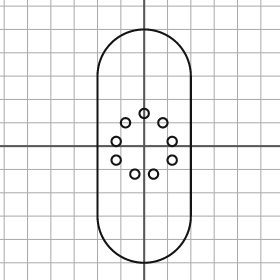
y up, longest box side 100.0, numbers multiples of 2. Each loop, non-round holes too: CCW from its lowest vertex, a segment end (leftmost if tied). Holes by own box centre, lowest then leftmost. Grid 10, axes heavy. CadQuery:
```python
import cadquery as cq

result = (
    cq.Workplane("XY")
    .moveTo(-20.0, -30.0)
    .threePointArc((0.0, -50.0), (20.0, -30.0))
    .lineTo(20.0, 30.0)
    .threePointArc((0.0, 50.0), (-20.0, 30.0))
    .close()
    .moveTo(-4.0, -12.0)
    .circle(2.0)
    .moveTo(4.0, -12.0)
    .circle(2.0)
    .moveTo(-12.0, -6.0)
    .circle(2.0)
    .moveTo(12.0, -6.0)
    .circle(2.0)
    .moveTo(-12.0, 2.0)
    .circle(2.0)
    .moveTo(12.0, 2.0)
    .circle(2.0)
    .moveTo(-8.0, 10.0)
    .circle(2.0)
    .moveTo(8.0, 10.0)
    .circle(2.0)
    .moveTo(0.0, 14.0)
    .circle(2.0)
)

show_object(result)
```